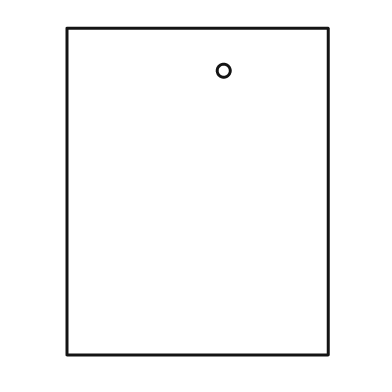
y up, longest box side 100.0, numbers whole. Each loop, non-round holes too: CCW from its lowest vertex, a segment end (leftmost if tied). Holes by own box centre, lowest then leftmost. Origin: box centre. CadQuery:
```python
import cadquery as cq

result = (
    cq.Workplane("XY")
    .moveTo(-40.0, -50.0)
    .lineTo(40.0, -50.0)
    .lineTo(40.0, 50.0)
    .lineTo(-40.0, 50.0)
    .close()
    .moveTo(8.0, 37.0)
    .circle(2.0)
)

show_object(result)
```